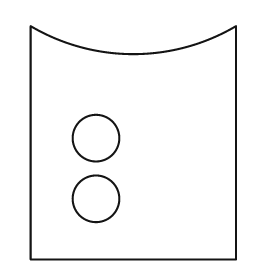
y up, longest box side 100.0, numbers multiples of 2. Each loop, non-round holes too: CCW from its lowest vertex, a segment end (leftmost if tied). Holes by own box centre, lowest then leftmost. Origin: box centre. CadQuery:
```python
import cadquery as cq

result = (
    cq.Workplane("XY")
    .moveTo(-44.0, -50.0)
    .lineTo(44.0, -50.0)
    .lineTo(44.0, 50.0)
    .threePointArc((0.0, 38.0), (-44.0, 50.0))
    .close()
    .moveTo(-16.0, -24.0)
    .circle(10.0)
    .moveTo(-16.0, 2.0)
    .circle(10.0)
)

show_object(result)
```